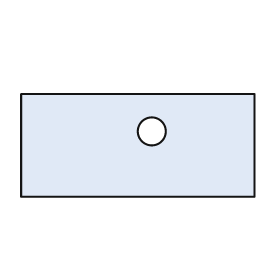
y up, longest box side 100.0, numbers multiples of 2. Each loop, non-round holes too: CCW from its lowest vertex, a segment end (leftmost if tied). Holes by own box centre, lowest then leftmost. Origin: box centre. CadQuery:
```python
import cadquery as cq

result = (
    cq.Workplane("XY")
    .moveTo(-50.0, -22.0)
    .lineTo(50.0, -22.0)
    .lineTo(50.0, 22.0)
    .lineTo(-50.0, 22.0)
    .close()
    .moveTo(6.0, 6.0)
    .circle(6.0)
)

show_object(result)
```